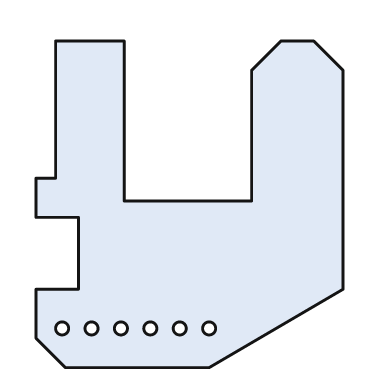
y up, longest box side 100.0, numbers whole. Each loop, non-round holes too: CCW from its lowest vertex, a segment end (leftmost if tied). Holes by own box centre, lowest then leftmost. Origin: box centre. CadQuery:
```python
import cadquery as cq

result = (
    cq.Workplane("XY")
    .moveTo(-38.0, -50.0)
    .lineTo(6.0, -50.0)
    .lineTo(47.0, -26.0)
    .lineTo(47.0, 41.0)
    .lineTo(38.0, 50.0)
    .lineTo(28.0, 50.0)
    .lineTo(19.0, 41.0)
    .lineTo(19.0, 1.0)
    .lineTo(-20.0, 1.0)
    .lineTo(-20.0, 50.0)
    .lineTo(-41.0, 50.0)
    .lineTo(-41.0, 8.0)
    .lineTo(-47.0, 8.0)
    .lineTo(-47.0, -4.0)
    .lineTo(-34.0, -4.0)
    .lineTo(-34.0, -26.0)
    .lineTo(-47.0, -26.0)
    .lineTo(-47.0, -41.0)
    .close()
    .moveTo(-39.0, -38.0)
    .circle(2.0)
    .moveTo(-30.0, -38.0)
    .circle(2.0)
    .moveTo(-21.0, -38.0)
    .circle(2.0)
    .moveTo(-12.0, -38.0)
    .circle(2.0)
    .moveTo(-3.0, -38.0)
    .circle(2.0)
    .moveTo(6.0, -38.0)
    .circle(2.0)
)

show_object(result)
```